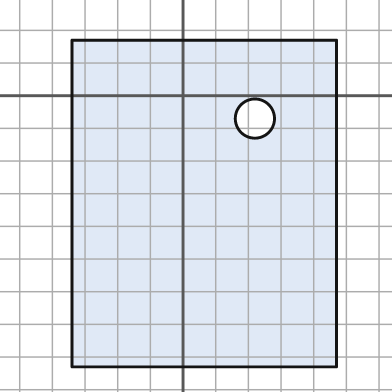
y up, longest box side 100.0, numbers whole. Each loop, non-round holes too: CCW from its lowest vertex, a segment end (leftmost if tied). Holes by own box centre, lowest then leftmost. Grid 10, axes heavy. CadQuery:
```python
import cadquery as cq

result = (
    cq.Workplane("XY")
    .moveTo(-34.0, -83.0)
    .lineTo(47.0, -83.0)
    .lineTo(47.0, 17.0)
    .lineTo(-34.0, 17.0)
    .close()
    .moveTo(22.0, -7.0)
    .circle(6.0)
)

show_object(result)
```